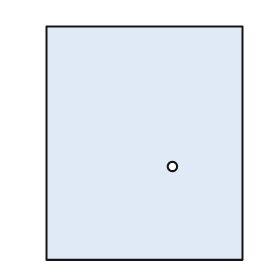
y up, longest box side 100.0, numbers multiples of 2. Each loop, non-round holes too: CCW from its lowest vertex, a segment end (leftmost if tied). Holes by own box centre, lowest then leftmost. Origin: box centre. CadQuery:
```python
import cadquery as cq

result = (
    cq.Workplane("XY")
    .moveTo(-42.0, -50.0)
    .lineTo(42.0, -50.0)
    .lineTo(42.0, 50.0)
    .lineTo(-42.0, 50.0)
    .close()
    .moveTo(12.0, -10.0)
    .circle(2.0)
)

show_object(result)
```